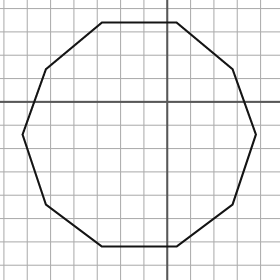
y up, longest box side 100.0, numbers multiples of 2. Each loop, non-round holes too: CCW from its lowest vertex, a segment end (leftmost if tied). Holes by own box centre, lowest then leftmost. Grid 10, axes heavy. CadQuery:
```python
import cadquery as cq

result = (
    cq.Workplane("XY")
    .moveTo(-28.0, -62.0)
    .lineTo(4.0, -62.0)
    .lineTo(28.0, -44.0)
    .lineTo(38.0, -14.0)
    .lineTo(28.0, 14.0)
    .lineTo(4.0, 34.0)
    .lineTo(-28.0, 34.0)
    .lineTo(-52.0, 14.0)
    .lineTo(-62.0, -14.0)
    .lineTo(-52.0, -44.0)
    .close()
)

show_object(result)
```